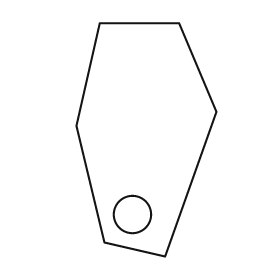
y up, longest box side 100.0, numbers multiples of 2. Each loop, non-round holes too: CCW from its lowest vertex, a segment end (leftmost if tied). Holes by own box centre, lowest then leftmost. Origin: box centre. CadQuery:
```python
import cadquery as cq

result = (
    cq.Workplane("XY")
    .moveTo(8.0, -50.0)
    .lineTo(30.0, 12.0)
    .lineTo(14.0, 50.0)
    .lineTo(-20.0, 50.0)
    .lineTo(-30.0, 6.0)
    .lineTo(-18.0, -44.0)
    .close()
    .moveTo(-6.0, -32.0)
    .circle(8.0)
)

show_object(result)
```